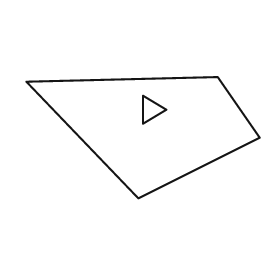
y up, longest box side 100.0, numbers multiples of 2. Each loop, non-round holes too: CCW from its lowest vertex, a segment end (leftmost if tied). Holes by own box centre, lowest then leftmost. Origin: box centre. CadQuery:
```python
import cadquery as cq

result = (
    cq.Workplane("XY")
    .moveTo(-2.0, -26.0)
    .lineTo(50.0, 0.0)
    .lineTo(32.0, 26.0)
    .lineTo(-50.0, 24.0)
    .close()
    .moveTo(0.0, 6.0)
    .lineTo(10.0, 12.0)
    .lineTo(0.0, 18.0)
    .close()
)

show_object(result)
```